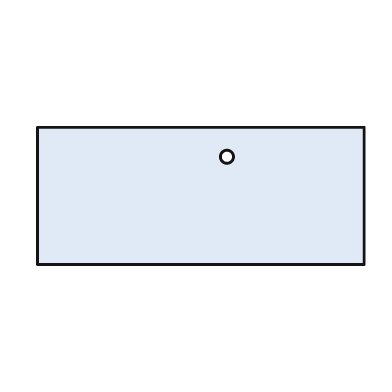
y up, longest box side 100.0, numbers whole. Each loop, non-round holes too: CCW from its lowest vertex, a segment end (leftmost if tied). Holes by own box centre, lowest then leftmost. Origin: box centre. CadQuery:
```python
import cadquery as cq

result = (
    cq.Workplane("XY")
    .moveTo(-50.0, -21.0)
    .lineTo(50.0, -21.0)
    .lineTo(50.0, 21.0)
    .lineTo(-50.0, 21.0)
    .close()
    .moveTo(8.0, 12.0)
    .circle(2.0)
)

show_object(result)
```